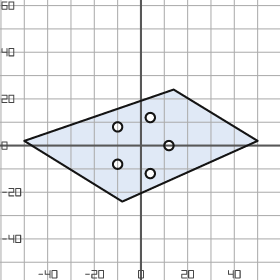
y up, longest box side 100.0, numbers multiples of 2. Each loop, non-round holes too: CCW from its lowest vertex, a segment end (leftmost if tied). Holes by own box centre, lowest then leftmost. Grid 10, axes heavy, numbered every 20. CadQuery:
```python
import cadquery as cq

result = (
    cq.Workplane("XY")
    .moveTo(-8.0, -24.0)
    .lineTo(50.0, 2.0)
    .lineTo(14.0, 24.0)
    .lineTo(-50.0, 2.0)
    .close()
    .moveTo(4.0, -12.0)
    .circle(2.0)
    .moveTo(-10.0, -8.0)
    .circle(2.0)
    .moveTo(12.0, 0.0)
    .circle(2.0)
    .moveTo(-10.0, 8.0)
    .circle(2.0)
    .moveTo(4.0, 12.0)
    .circle(2.0)
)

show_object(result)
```